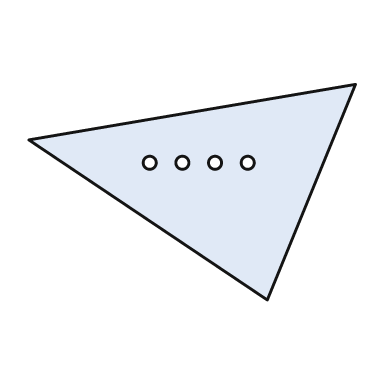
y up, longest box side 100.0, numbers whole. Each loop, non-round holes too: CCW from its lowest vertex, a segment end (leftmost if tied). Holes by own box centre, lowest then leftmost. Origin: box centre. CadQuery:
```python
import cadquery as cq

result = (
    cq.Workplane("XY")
    .moveTo(23.0, -33.0)
    .lineTo(50.0, 33.0)
    .lineTo(-50.0, 16.0)
    .close()
    .moveTo(-13.0, 9.0)
    .circle(2.0)
    .moveTo(-3.0, 9.0)
    .circle(2.0)
    .moveTo(7.0, 9.0)
    .circle(2.0)
    .moveTo(17.0, 9.0)
    .circle(2.0)
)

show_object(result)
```